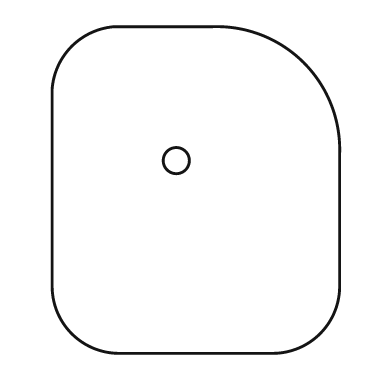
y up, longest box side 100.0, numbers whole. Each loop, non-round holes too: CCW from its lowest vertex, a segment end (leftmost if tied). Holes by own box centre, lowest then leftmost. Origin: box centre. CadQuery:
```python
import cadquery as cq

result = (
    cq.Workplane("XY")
    .moveTo(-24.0, -50.0)
    .lineTo(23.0, -50.0)
    .threePointArc((38.0, -44.0), (44.0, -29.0))
    .lineTo(44.0, 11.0)
    .threePointArc((33.0, 39.0), (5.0, 50.0))
    .lineTo(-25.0, 50.0)
    .threePointArc((-38.0, 44.0), (-44.0, 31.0))
    .lineTo(-44.0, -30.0)
    .threePointArc((-38.0, -44.0), (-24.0, -50.0))
    .close()
    .moveTo(-6.0, 9.0)
    .circle(4.0)
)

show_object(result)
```